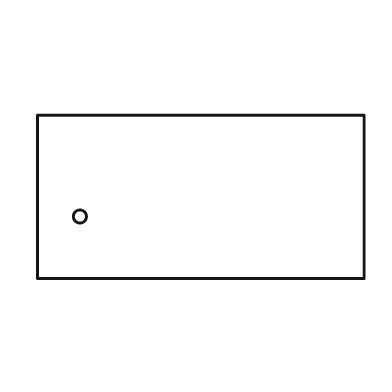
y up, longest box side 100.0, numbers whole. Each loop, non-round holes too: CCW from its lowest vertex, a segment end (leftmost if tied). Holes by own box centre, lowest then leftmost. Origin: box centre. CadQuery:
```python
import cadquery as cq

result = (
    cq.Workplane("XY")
    .moveTo(-50.0, -25.0)
    .lineTo(50.0, -25.0)
    .lineTo(50.0, 25.0)
    .lineTo(-50.0, 25.0)
    .close()
    .moveTo(-37.0, -6.0)
    .circle(2.0)
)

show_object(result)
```